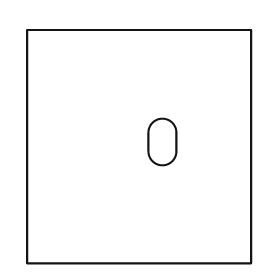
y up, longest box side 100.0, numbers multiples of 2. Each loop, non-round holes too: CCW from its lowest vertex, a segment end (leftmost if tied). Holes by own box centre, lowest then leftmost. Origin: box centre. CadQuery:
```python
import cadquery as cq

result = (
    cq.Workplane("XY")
    .moveTo(-48.0, -50.0)
    .lineTo(48.0, -50.0)
    .lineTo(48.0, 50.0)
    .lineTo(-48.0, 50.0)
    .close()
    .moveTo(4.0, -2.0)
    .threePointArc((10.0, -8.0), (16.0, -2.0))
    .lineTo(16.0, 6.0)
    .threePointArc((10.0, 12.0), (4.0, 6.0))
    .close()
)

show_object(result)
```